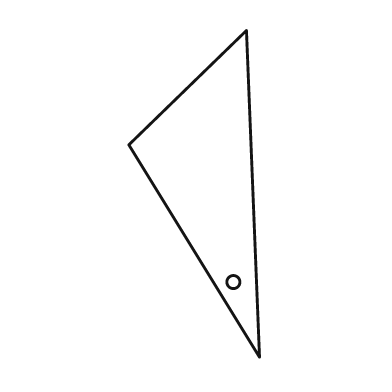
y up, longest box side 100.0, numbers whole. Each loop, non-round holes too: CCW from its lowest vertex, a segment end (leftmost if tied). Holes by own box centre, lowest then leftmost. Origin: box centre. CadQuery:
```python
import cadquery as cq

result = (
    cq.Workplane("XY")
    .moveTo(20.0, -50.0)
    .lineTo(16.0, 50.0)
    .lineTo(-20.0, 15.0)
    .close()
    .moveTo(12.0, -27.0)
    .circle(2.0)
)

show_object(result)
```